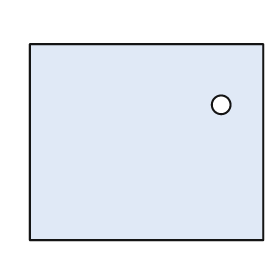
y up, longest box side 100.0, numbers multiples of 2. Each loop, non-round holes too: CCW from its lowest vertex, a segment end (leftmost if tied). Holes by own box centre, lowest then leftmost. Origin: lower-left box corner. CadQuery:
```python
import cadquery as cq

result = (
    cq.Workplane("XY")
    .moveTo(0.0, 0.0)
    .lineTo(100.0, 0.0)
    .lineTo(100.0, 84.0)
    .lineTo(0.0, 84.0)
    .close()
    .moveTo(82.0, 58.0)
    .circle(4.0)
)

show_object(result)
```